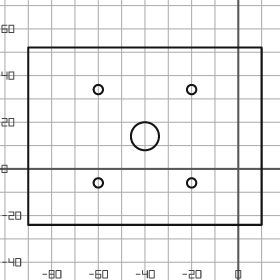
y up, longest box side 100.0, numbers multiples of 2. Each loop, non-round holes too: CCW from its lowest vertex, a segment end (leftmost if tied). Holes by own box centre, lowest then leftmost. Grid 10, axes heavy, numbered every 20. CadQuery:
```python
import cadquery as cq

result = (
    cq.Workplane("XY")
    .moveTo(-90.0, -24.0)
    .lineTo(10.0, -24.0)
    .lineTo(10.0, 52.0)
    .lineTo(-90.0, 52.0)
    .close()
    .moveTo(-60.0, -6.0)
    .circle(2.0)
    .moveTo(-20.0, -6.0)
    .circle(2.0)
    .moveTo(-40.0, 14.0)
    .circle(6.0)
    .moveTo(-60.0, 34.0)
    .circle(2.0)
    .moveTo(-20.0, 34.0)
    .circle(2.0)
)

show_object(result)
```